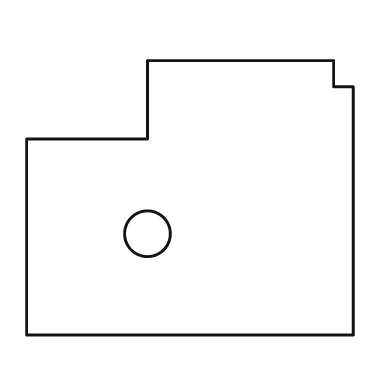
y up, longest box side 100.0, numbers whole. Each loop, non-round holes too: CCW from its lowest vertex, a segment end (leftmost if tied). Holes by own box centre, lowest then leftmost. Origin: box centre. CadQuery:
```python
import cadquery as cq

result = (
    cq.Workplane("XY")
    .moveTo(-50.0, -42.0)
    .lineTo(50.0, -42.0)
    .lineTo(50.0, 34.0)
    .lineTo(44.0, 34.0)
    .lineTo(44.0, 42.0)
    .lineTo(-13.0, 42.0)
    .lineTo(-13.0, 18.0)
    .lineTo(-50.0, 18.0)
    .close()
    .moveTo(-13.0, -11.0)
    .circle(7.0)
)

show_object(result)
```